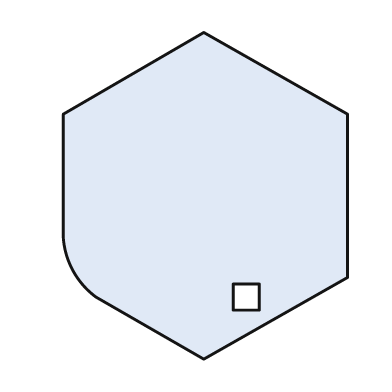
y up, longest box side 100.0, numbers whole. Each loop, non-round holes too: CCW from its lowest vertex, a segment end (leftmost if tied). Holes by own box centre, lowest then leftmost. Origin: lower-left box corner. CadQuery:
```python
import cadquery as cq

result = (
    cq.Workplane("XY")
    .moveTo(43.0, 0.0)
    .lineTo(87.0, 25.0)
    .lineTo(87.0, 75.0)
    .lineTo(43.0, 100.0)
    .lineTo(0.0, 75.0)
    .lineTo(0.0, 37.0)
    .threePointArc((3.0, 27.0), (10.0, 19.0))
    .close()
    .moveTo(52.0, 15.0)
    .lineTo(60.0, 15.0)
    .lineTo(60.0, 23.0)
    .lineTo(52.0, 23.0)
    .close()
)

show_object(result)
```